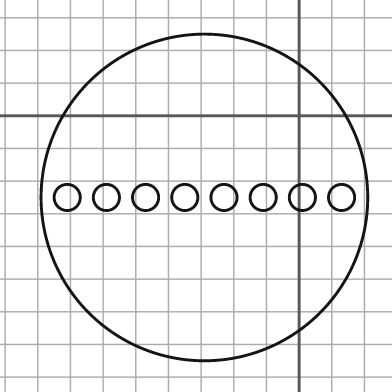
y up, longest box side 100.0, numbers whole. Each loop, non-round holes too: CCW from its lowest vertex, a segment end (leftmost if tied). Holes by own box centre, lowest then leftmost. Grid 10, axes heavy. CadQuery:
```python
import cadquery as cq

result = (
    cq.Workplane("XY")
    .moveTo(-29.0, -25.0)
    .circle(50.0)
    .moveTo(-71.0, -25.0)
    .circle(4.0)
    .moveTo(-59.0, -25.0)
    .circle(4.0)
    .moveTo(-47.0, -25.0)
    .circle(4.0)
    .moveTo(-35.0, -25.0)
    .circle(4.0)
    .moveTo(-23.0, -25.0)
    .circle(4.0)
    .moveTo(-11.0, -25.0)
    .circle(4.0)
    .moveTo(1.0, -25.0)
    .circle(4.0)
    .moveTo(13.0, -25.0)
    .circle(4.0)
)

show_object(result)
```